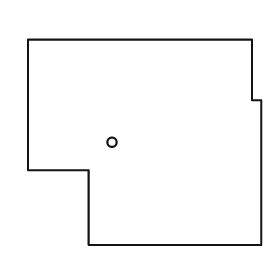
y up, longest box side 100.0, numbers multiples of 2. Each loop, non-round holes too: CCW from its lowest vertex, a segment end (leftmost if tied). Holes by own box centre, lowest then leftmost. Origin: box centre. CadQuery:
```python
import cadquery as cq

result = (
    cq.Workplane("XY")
    .moveTo(-24.0, -44.0)
    .lineTo(50.0, -44.0)
    .lineTo(50.0, 18.0)
    .lineTo(46.0, 18.0)
    .lineTo(46.0, 44.0)
    .lineTo(-50.0, 44.0)
    .lineTo(-50.0, -12.0)
    .lineTo(-24.0, -12.0)
    .close()
    .moveTo(-14.0, 0.0)
    .circle(2.0)
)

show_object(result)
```